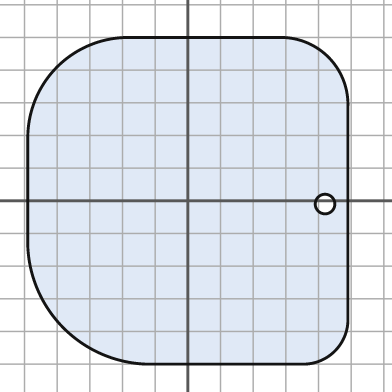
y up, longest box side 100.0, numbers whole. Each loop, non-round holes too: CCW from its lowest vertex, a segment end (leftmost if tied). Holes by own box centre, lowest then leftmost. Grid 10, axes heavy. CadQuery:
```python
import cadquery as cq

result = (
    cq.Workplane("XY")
    .moveTo(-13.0, -50.0)
    .lineTo(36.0, -50.0)
    .threePointArc((45.0, -46.0), (49.0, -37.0))
    .lineTo(49.0, 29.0)
    .threePointArc((43.0, 44.0), (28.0, 50.0))
    .lineTo(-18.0, 50.0)
    .threePointArc((-40.0, 41.0), (-49.0, 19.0))
    .lineTo(-49.0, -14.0)
    .threePointArc((-38.0, -39.0), (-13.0, -50.0))
    .close()
    .moveTo(42.0, -1.0)
    .circle(3.0)
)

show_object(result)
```